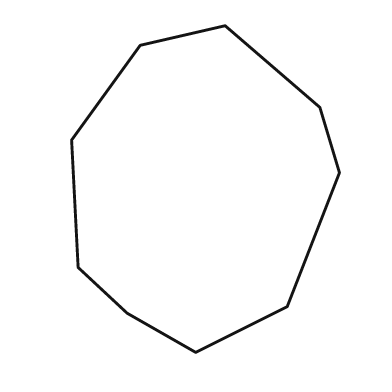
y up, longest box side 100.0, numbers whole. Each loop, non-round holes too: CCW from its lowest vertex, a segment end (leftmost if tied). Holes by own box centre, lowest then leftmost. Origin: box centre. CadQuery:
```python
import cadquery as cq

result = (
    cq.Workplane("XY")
    .moveTo(-3.0, -50.0)
    .lineTo(25.0, -36.0)
    .lineTo(41.0, 5.0)
    .lineTo(35.0, 25.0)
    .lineTo(6.0, 50.0)
    .lineTo(-20.0, 44.0)
    .lineTo(-41.0, 15.0)
    .lineTo(-39.0, -24.0)
    .lineTo(-24.0, -38.0)
    .close()
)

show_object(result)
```